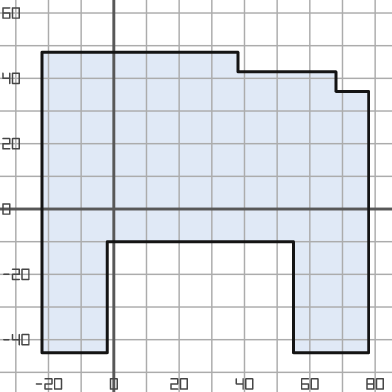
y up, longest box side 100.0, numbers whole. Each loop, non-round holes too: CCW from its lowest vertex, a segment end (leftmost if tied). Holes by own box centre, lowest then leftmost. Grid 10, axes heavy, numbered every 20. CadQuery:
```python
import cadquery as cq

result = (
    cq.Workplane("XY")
    .moveTo(-22.0, -44.0)
    .lineTo(-2.0, -44.0)
    .lineTo(-2.0, -10.0)
    .lineTo(55.0, -10.0)
    .lineTo(55.0, -44.0)
    .lineTo(78.0, -44.0)
    .lineTo(78.0, 36.0)
    .lineTo(68.0, 36.0)
    .lineTo(68.0, 42.0)
    .lineTo(38.0, 42.0)
    .lineTo(38.0, 48.0)
    .lineTo(-22.0, 48.0)
    .close()
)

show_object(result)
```